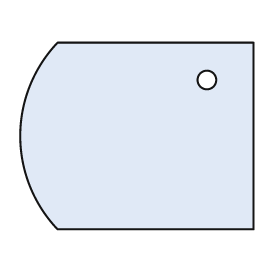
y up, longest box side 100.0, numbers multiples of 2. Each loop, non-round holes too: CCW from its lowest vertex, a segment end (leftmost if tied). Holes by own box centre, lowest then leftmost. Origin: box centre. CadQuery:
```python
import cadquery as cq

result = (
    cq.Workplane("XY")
    .moveTo(-34.0, -40.0)
    .lineTo(50.0, -40.0)
    .lineTo(50.0, 40.0)
    .lineTo(-34.0, 40.0)
    .threePointArc((-50.0, 0.0), (-34.0, -40.0))
    .close()
    .moveTo(30.0, 24.0)
    .circle(4.0)
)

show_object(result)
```